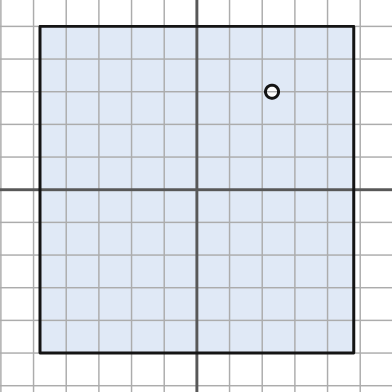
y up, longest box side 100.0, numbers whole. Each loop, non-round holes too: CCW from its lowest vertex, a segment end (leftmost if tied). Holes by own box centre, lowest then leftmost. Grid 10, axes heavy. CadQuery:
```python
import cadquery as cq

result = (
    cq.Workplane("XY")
    .moveTo(-48.0, -50.0)
    .lineTo(48.0, -50.0)
    .lineTo(48.0, 50.0)
    .lineTo(-48.0, 50.0)
    .close()
    .moveTo(23.0, 30.0)
    .circle(2.0)
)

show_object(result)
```